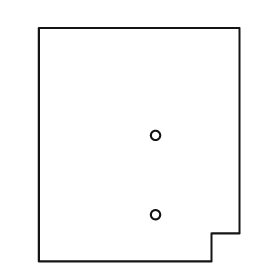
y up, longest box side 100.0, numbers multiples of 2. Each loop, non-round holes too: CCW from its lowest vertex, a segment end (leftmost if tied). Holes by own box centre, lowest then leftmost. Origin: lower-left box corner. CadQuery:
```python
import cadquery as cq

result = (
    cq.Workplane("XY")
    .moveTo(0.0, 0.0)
    .lineTo(74.0, 0.0)
    .lineTo(74.0, 12.0)
    .lineTo(86.0, 12.0)
    .lineTo(86.0, 100.0)
    .lineTo(0.0, 100.0)
    .close()
    .moveTo(50.0, 20.0)
    .circle(2.0)
    .moveTo(50.0, 54.0)
    .circle(2.0)
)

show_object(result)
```